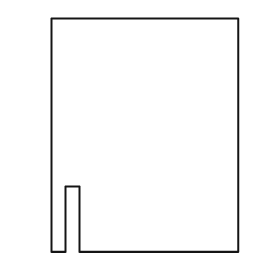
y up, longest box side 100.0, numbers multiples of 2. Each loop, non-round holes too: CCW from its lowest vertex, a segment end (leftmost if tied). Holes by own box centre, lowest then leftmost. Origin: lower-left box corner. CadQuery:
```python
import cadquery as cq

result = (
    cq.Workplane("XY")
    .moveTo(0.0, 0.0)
    .lineTo(6.0, 0.0)
    .lineTo(6.0, 28.0)
    .lineTo(12.0, 28.0)
    .lineTo(12.0, 0.0)
    .lineTo(80.0, 0.0)
    .lineTo(80.0, 100.0)
    .lineTo(0.0, 100.0)
    .close()
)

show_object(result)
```